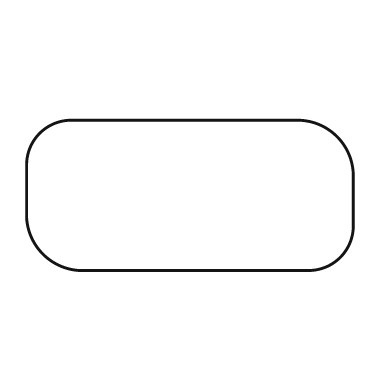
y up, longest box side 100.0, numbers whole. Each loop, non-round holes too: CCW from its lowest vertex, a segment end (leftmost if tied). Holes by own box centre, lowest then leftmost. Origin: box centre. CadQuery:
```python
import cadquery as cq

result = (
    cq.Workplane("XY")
    .moveTo(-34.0, -23.0)
    .lineTo(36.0, -23.0)
    .threePointArc((46.0, -19.0), (50.0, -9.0))
    .lineTo(50.0, 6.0)
    .threePointArc((45.0, 18.0), (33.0, 23.0))
    .lineTo(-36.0, 23.0)
    .threePointArc((-46.0, 19.0), (-50.0, 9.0))
    .lineTo(-50.0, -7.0)
    .threePointArc((-45.0, -18.0), (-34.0, -23.0))
    .close()
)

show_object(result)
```